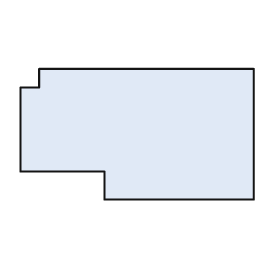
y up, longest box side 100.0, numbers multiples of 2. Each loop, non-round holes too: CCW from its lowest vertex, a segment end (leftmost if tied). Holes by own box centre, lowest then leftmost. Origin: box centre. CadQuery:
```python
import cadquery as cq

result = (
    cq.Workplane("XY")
    .moveTo(-14.0, -28.0)
    .lineTo(50.0, -28.0)
    .lineTo(50.0, 28.0)
    .lineTo(-42.0, 28.0)
    .lineTo(-42.0, 20.0)
    .lineTo(-50.0, 20.0)
    .lineTo(-50.0, -16.0)
    .lineTo(-14.0, -16.0)
    .close()
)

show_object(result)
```